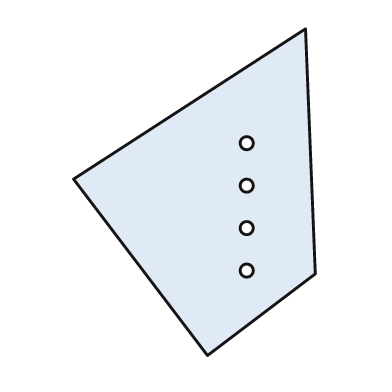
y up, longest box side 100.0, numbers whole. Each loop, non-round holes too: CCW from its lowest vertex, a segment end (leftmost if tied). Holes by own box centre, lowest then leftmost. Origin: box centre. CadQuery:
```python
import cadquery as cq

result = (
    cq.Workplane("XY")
    .moveTo(4.0, -50.0)
    .lineTo(37.0, -25.0)
    .lineTo(34.0, 50.0)
    .lineTo(-37.0, 4.0)
    .close()
    .moveTo(16.0, -24.0)
    .circle(2.0)
    .moveTo(16.0, -11.0)
    .circle(2.0)
    .moveTo(16.0, 2.0)
    .circle(2.0)
    .moveTo(16.0, 15.0)
    .circle(2.0)
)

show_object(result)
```